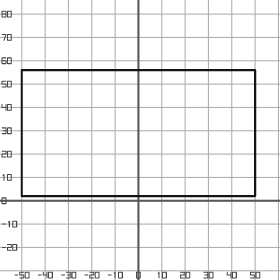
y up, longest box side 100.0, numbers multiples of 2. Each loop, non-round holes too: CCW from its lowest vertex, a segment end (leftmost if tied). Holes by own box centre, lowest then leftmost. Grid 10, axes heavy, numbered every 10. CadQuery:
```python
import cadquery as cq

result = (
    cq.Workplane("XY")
    .moveTo(-50.0, 2.0)
    .lineTo(50.0, 2.0)
    .lineTo(50.0, 56.0)
    .lineTo(-50.0, 56.0)
    .close()
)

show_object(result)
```